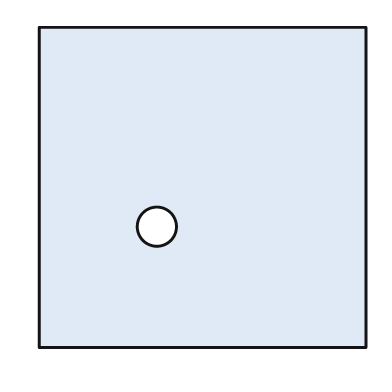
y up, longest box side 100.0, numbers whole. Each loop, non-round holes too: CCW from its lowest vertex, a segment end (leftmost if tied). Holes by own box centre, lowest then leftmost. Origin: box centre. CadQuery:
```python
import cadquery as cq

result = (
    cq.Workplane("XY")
    .moveTo(-50.0, -49.0)
    .lineTo(50.0, -49.0)
    .lineTo(50.0, 49.0)
    .lineTo(-50.0, 49.0)
    .close()
    .moveTo(-14.0, -12.0)
    .circle(6.0)
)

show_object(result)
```